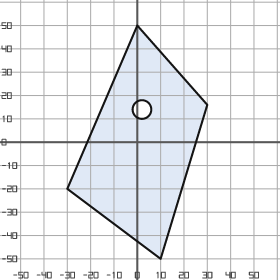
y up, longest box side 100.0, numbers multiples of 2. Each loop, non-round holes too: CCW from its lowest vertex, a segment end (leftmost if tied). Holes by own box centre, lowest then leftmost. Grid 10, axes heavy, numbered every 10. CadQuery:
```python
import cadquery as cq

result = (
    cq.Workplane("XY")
    .moveTo(10.0, -50.0)
    .lineTo(30.0, 16.0)
    .lineTo(0.0, 50.0)
    .lineTo(-30.0, -20.0)
    .close()
    .moveTo(2.0, 14.0)
    .circle(4.0)
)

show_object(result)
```